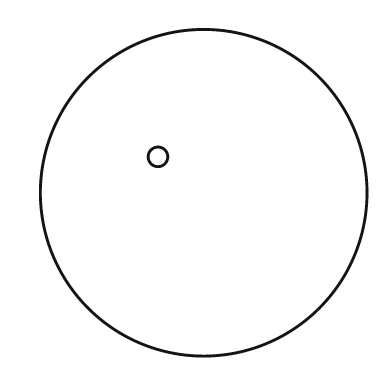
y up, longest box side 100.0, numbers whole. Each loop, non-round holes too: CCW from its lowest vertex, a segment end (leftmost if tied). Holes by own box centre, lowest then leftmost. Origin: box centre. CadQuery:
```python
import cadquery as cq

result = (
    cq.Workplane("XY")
    .moveTo(0.0, 0.0)
    .circle(50.0)
    .moveTo(-14.0, 11.0)
    .circle(3.0)
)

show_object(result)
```